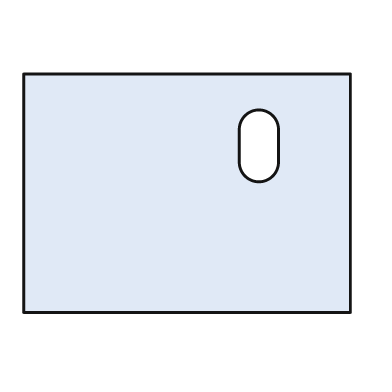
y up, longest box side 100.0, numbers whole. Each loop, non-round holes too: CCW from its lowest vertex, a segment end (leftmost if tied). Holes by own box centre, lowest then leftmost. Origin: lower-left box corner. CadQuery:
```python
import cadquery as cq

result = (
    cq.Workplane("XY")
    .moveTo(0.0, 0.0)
    .lineTo(100.0, 0.0)
    .lineTo(100.0, 73.0)
    .lineTo(0.0, 73.0)
    .close()
    .moveTo(66.0, 46.0)
    .threePointArc((72.0, 40.0), (78.0, 46.0))
    .lineTo(78.0, 56.0)
    .threePointArc((72.0, 62.0), (66.0, 56.0))
    .close()
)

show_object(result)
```